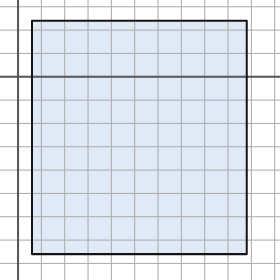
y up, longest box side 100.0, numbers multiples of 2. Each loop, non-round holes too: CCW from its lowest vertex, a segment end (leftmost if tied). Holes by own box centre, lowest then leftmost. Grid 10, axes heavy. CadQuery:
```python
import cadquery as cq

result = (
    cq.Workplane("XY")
    .moveTo(6.0, -76.0)
    .lineTo(98.0, -76.0)
    .lineTo(98.0, 24.0)
    .lineTo(6.0, 24.0)
    .close()
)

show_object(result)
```